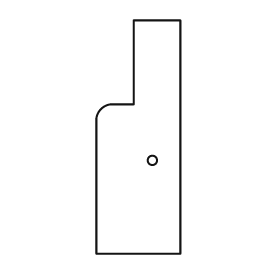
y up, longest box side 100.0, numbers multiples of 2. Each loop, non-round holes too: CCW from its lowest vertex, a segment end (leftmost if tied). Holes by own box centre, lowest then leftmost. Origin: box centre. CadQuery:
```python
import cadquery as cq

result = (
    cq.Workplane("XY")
    .moveTo(-18.0, -50.0)
    .lineTo(18.0, -50.0)
    .lineTo(18.0, 50.0)
    .lineTo(-2.0, 50.0)
    .lineTo(-2.0, 14.0)
    .lineTo(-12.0, 14.0)
    .threePointArc((-16.0, 12.0), (-18.0, 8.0))
    .close()
    .moveTo(6.0, -10.0)
    .circle(2.0)
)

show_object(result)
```